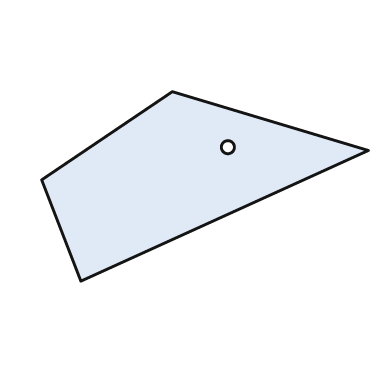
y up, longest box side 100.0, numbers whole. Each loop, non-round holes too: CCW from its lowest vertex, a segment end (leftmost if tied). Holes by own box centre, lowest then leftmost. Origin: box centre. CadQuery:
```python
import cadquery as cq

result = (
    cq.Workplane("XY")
    .moveTo(-38.0, -29.0)
    .lineTo(50.0, 11.0)
    .lineTo(-10.0, 29.0)
    .lineTo(-50.0, 2.0)
    .close()
    .moveTo(7.0, 12.0)
    .circle(2.0)
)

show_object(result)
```